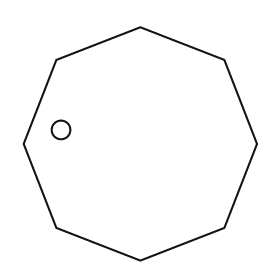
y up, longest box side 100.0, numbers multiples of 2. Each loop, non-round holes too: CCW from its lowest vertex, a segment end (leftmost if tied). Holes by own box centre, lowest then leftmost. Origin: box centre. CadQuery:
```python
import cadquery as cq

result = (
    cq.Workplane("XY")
    .moveTo(0.0, -50.0)
    .lineTo(36.0, -36.0)
    .lineTo(50.0, 0.0)
    .lineTo(36.0, 36.0)
    .lineTo(0.0, 50.0)
    .lineTo(-36.0, 36.0)
    .lineTo(-50.0, 0.0)
    .lineTo(-36.0, -36.0)
    .close()
    .moveTo(-34.0, 6.0)
    .circle(4.0)
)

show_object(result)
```